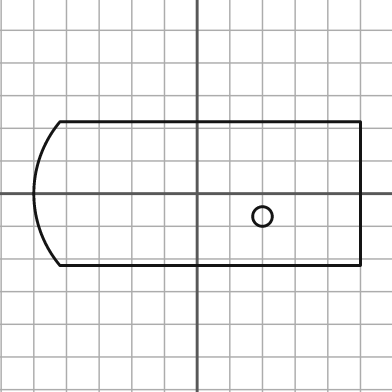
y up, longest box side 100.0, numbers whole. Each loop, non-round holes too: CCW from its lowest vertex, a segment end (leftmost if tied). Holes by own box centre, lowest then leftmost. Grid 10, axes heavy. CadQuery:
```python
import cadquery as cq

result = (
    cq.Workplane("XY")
    .moveTo(-42.0, -22.0)
    .lineTo(50.0, -22.0)
    .lineTo(50.0, 22.0)
    .lineTo(-42.0, 22.0)
    .threePointArc((-50.0, 0.0), (-42.0, -22.0))
    .close()
    .moveTo(20.0, -7.0)
    .circle(3.0)
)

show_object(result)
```